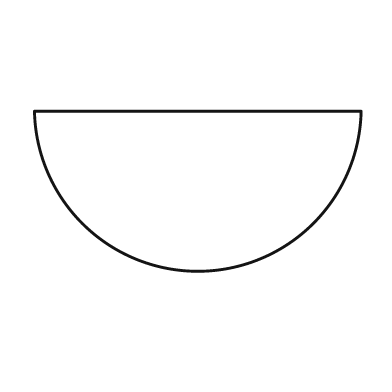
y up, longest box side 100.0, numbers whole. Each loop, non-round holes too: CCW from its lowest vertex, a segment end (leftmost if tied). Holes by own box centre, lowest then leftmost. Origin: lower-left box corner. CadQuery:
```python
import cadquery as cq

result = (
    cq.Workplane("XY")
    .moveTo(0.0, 49.0)
    .threePointArc((50.0, 0.0), (100.0, 49.0))
    .close()
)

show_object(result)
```